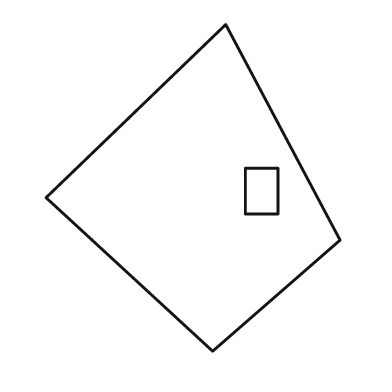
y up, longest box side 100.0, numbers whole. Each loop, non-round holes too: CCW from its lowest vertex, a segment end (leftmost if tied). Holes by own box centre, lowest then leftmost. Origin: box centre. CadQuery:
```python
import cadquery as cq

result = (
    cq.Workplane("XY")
    .moveTo(6.0, -50.0)
    .lineTo(45.0, -16.0)
    .lineTo(10.0, 50.0)
    .lineTo(-45.0, -3.0)
    .close()
    .moveTo(16.0, -8.0)
    .lineTo(26.0, -8.0)
    .lineTo(26.0, 6.0)
    .lineTo(16.0, 6.0)
    .close()
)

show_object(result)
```